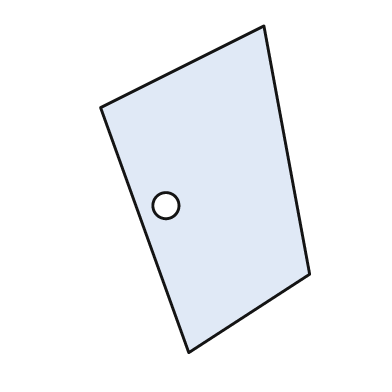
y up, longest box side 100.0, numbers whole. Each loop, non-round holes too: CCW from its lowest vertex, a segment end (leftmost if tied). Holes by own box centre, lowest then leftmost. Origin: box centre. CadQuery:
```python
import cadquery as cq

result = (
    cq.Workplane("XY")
    .moveTo(-5.0, -50.0)
    .lineTo(32.0, -26.0)
    .lineTo(18.0, 50.0)
    .lineTo(-32.0, 25.0)
    .close()
    .moveTo(-12.0, -5.0)
    .circle(4.0)
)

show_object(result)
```